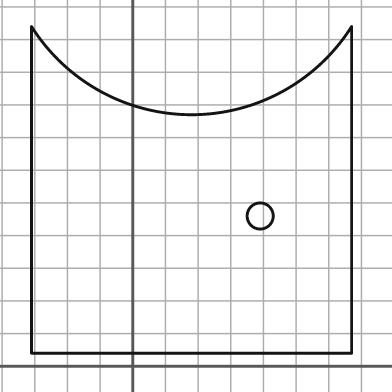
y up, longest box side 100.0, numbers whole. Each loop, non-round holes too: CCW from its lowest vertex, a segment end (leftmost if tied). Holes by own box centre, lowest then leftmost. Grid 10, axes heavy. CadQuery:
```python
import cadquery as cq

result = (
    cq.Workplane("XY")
    .moveTo(-31.0, 4.0)
    .lineTo(67.0, 4.0)
    .lineTo(67.0, 104.0)
    .threePointArc((18.0, 77.0), (-31.0, 104.0))
    .close()
    .moveTo(39.0, 46.0)
    .circle(4.0)
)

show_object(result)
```